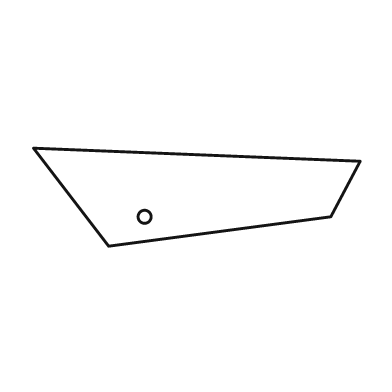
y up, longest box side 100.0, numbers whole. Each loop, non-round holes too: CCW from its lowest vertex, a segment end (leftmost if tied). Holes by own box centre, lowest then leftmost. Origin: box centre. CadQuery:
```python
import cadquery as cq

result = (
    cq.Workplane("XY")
    .moveTo(-27.0, -15.0)
    .lineTo(41.0, -6.0)
    .lineTo(50.0, 11.0)
    .lineTo(-50.0, 15.0)
    .close()
    .moveTo(-16.0, -6.0)
    .circle(2.0)
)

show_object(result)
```